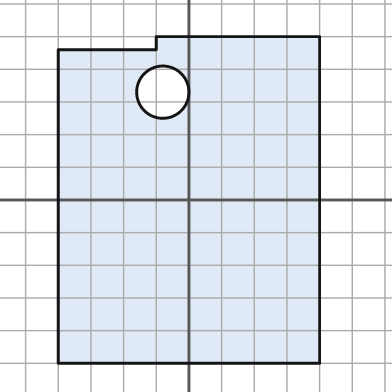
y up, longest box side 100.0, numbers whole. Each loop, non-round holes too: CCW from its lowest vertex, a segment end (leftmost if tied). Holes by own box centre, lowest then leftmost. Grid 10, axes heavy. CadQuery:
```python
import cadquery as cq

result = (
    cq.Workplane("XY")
    .moveTo(-40.0, -50.0)
    .lineTo(40.0, -50.0)
    .lineTo(40.0, 50.0)
    .lineTo(-10.0, 50.0)
    .lineTo(-10.0, 46.0)
    .lineTo(-40.0, 46.0)
    .close()
    .moveTo(-8.0, 33.0)
    .circle(8.0)
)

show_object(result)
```